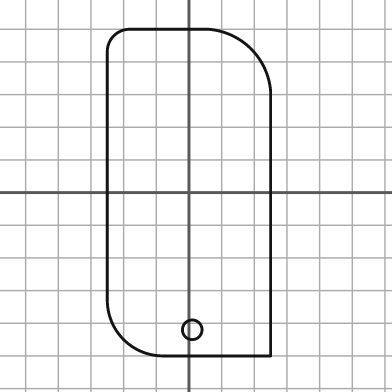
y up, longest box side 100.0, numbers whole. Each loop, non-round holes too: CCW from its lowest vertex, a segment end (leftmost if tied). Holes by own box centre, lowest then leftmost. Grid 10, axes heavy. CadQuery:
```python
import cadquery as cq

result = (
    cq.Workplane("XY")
    .moveTo(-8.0, -50.0)
    .lineTo(25.0, -50.0)
    .lineTo(25.0, 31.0)
    .threePointArc((19.0, 44.0), (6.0, 50.0))
    .lineTo(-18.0, 50.0)
    .threePointArc((-23.0, 48.0), (-25.0, 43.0))
    .lineTo(-25.0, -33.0)
    .threePointArc((-20.0, -45.0), (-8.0, -50.0))
    .close()
    .moveTo(1.0, -42.0)
    .circle(3.0)
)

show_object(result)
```